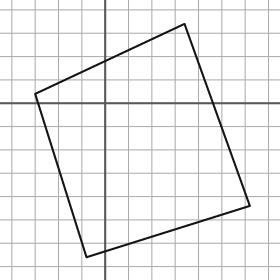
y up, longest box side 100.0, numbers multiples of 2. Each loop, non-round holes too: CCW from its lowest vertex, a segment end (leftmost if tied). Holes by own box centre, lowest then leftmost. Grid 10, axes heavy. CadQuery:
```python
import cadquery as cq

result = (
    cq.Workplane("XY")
    .moveTo(-8.0, -66.0)
    .lineTo(62.0, -44.0)
    .lineTo(34.0, 34.0)
    .lineTo(-30.0, 4.0)
    .close()
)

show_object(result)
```